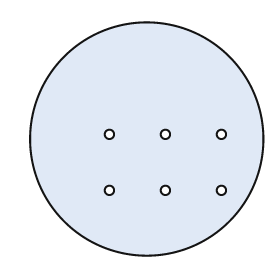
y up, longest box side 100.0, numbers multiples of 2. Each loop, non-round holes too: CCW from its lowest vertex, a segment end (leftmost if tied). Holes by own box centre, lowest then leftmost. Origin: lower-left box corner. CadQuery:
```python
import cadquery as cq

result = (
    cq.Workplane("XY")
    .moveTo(50.0, 50.0)
    .circle(50.0)
    .moveTo(34.0, 28.0)
    .circle(2.0)
    .moveTo(58.0, 28.0)
    .circle(2.0)
    .moveTo(82.0, 28.0)
    .circle(2.0)
    .moveTo(34.0, 52.0)
    .circle(2.0)
    .moveTo(58.0, 52.0)
    .circle(2.0)
    .moveTo(82.0, 52.0)
    .circle(2.0)
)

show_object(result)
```